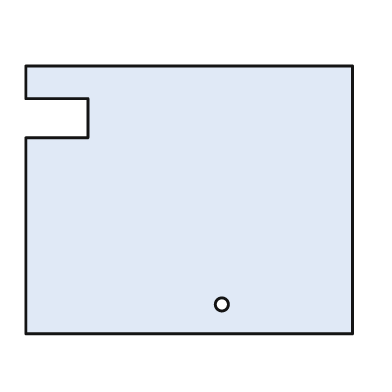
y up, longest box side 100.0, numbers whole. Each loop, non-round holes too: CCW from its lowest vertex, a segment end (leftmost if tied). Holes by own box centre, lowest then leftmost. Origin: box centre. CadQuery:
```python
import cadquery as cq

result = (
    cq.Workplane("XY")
    .moveTo(-50.0, -41.0)
    .lineTo(50.0, -41.0)
    .lineTo(50.0, 41.0)
    .lineTo(-50.0, 41.0)
    .lineTo(-50.0, 31.0)
    .lineTo(-31.0, 31.0)
    .lineTo(-31.0, 19.0)
    .lineTo(-50.0, 19.0)
    .close()
    .moveTo(10.0, -32.0)
    .circle(2.0)
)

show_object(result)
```